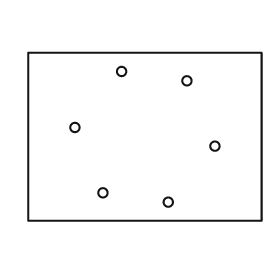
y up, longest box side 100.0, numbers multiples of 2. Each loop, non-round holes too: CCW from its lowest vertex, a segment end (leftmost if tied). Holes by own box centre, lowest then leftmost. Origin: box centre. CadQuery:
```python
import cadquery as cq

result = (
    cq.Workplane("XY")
    .moveTo(-50.0, -36.0)
    .lineTo(50.0, -36.0)
    .lineTo(50.0, 36.0)
    .lineTo(-50.0, 36.0)
    .close()
    .moveTo(10.0, -28.0)
    .circle(2.0)
    .moveTo(-18.0, -24.0)
    .circle(2.0)
    .moveTo(30.0, -4.0)
    .circle(2.0)
    .moveTo(-30.0, 4.0)
    .circle(2.0)
    .moveTo(18.0, 24.0)
    .circle(2.0)
    .moveTo(-10.0, 28.0)
    .circle(2.0)
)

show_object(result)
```